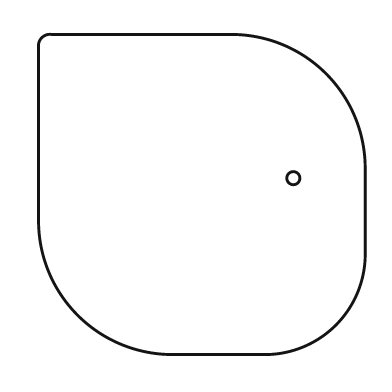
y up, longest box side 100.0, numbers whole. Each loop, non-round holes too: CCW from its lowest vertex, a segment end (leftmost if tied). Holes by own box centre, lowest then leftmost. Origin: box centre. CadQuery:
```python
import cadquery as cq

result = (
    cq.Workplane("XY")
    .moveTo(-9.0, -49.0)
    .lineTo(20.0, -49.0)
    .threePointArc((41.0, -40.0), (50.0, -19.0))
    .lineTo(50.0, 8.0)
    .threePointArc((38.0, 37.0), (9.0, 49.0))
    .lineTo(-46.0, 49.0)
    .threePointArc((-49.0, 48.0), (-50.0, 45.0))
    .lineTo(-50.0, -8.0)
    .threePointArc((-38.0, -37.0), (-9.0, -49.0))
    .close()
    .moveTo(28.0, 5.0)
    .circle(2.0)
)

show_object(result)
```